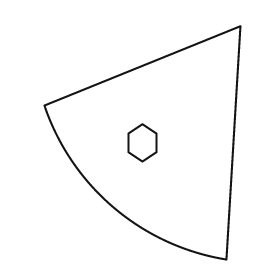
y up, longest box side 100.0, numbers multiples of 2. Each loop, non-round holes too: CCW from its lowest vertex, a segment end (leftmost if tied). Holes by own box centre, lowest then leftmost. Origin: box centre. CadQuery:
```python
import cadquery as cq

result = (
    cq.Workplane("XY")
    .moveTo(36.0, -50.0)
    .lineTo(42.0, 50.0)
    .lineTo(-42.0, 16.0)
    .threePointArc((-12.0, -28.0), (36.0, -50.0))
    .close()
    .moveTo(0.0, -8.0)
    .lineTo(6.0, -4.0)
    .lineTo(6.0, 4.0)
    .lineTo(0.0, 8.0)
    .lineTo(-6.0, 4.0)
    .lineTo(-6.0, -4.0)
    .close()
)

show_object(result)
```